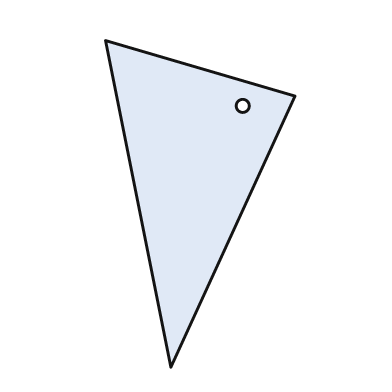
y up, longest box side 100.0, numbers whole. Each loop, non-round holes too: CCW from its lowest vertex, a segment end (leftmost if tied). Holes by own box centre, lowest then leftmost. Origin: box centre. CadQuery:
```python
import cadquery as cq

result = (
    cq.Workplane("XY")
    .moveTo(-9.0, -50.0)
    .lineTo(29.0, 33.0)
    .lineTo(-29.0, 50.0)
    .close()
    .moveTo(13.0, 30.0)
    .circle(2.0)
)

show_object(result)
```